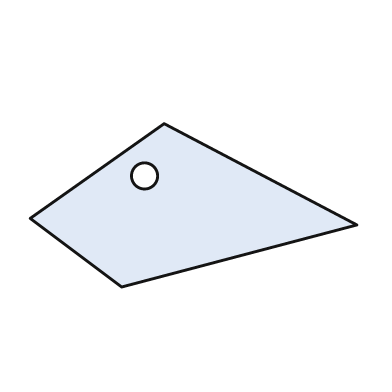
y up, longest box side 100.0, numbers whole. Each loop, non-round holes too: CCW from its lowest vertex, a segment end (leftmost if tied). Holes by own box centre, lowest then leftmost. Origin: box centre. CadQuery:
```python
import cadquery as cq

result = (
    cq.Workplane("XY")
    .moveTo(-22.0, -25.0)
    .lineTo(50.0, -6.0)
    .lineTo(-9.0, 25.0)
    .lineTo(-50.0, -4.0)
    .close()
    .moveTo(-15.0, 9.0)
    .circle(4.0)
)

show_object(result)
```